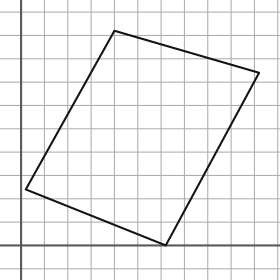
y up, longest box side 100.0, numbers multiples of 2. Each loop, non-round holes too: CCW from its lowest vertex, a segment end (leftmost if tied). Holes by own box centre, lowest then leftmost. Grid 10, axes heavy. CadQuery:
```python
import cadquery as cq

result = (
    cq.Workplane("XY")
    .moveTo(62.0, 0.0)
    .lineTo(102.0, 74.0)
    .lineTo(40.0, 92.0)
    .lineTo(2.0, 24.0)
    .close()
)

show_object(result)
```